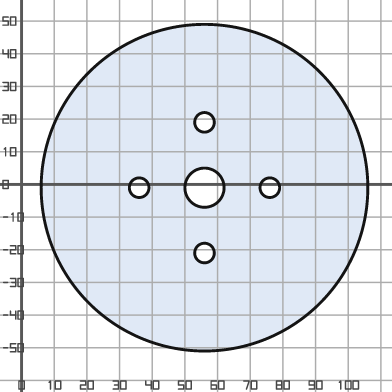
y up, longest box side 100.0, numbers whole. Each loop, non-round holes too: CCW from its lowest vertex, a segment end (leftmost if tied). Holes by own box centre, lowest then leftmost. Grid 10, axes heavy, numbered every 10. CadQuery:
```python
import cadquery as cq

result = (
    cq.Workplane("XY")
    .moveTo(56.0, -1.0)
    .circle(50.0)
    .moveTo(56.0, -21.0)
    .circle(3.0)
    .moveTo(36.0, -1.0)
    .circle(3.0)
    .moveTo(56.0, -1.0)
    .circle(6.0)
    .moveTo(76.0, -1.0)
    .circle(3.0)
    .moveTo(56.0, 19.0)
    .circle(3.0)
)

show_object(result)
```